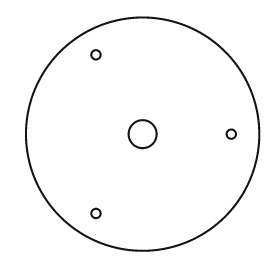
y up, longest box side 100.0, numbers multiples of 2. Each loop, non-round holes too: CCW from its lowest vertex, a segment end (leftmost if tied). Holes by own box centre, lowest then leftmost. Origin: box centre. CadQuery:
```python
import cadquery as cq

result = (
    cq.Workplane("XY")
    .moveTo(0.0, 0.0)
    .circle(50.0)
    .moveTo(-20.0, -34.0)
    .circle(2.0)
    .moveTo(0.0, 0.0)
    .circle(6.0)
    .moveTo(38.0, 0.0)
    .circle(2.0)
    .moveTo(-20.0, 34.0)
    .circle(2.0)
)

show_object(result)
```